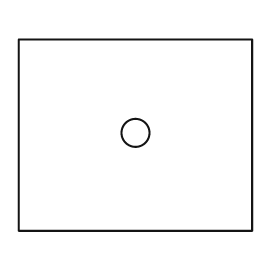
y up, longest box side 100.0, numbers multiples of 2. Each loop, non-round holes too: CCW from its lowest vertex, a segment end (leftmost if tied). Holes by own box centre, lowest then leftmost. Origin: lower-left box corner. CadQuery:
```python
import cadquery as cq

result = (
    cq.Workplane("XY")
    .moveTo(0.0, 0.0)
    .lineTo(100.0, 0.0)
    .lineTo(100.0, 82.0)
    .lineTo(0.0, 82.0)
    .close()
    .moveTo(50.0, 42.0)
    .circle(6.0)
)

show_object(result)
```